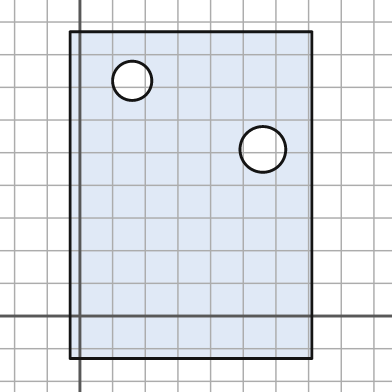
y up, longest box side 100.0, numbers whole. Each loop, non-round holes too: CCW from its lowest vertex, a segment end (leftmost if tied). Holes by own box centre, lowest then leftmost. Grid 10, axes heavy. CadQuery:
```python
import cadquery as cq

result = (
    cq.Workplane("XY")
    .moveTo(-3.0, -13.0)
    .lineTo(71.0, -13.0)
    .lineTo(71.0, 87.0)
    .lineTo(-3.0, 87.0)
    .close()
    .moveTo(56.0, 51.0)
    .circle(7.0)
    .moveTo(16.0, 72.0)
    .circle(6.0)
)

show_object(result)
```